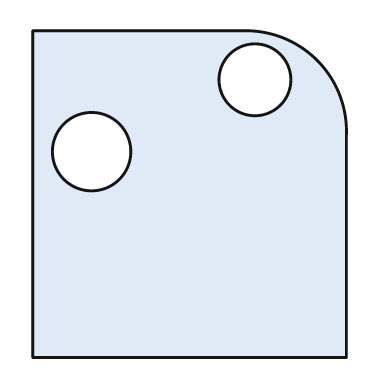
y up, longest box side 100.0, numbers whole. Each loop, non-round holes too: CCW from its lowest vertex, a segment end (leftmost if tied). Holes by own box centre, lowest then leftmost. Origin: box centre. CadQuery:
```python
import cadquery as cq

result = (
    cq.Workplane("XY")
    .moveTo(-48.0, -50.0)
    .lineTo(48.0, -50.0)
    .lineTo(48.0, 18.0)
    .threePointArc((39.0, 41.0), (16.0, 50.0))
    .lineTo(-48.0, 50.0)
    .close()
    .moveTo(-30.0, 13.0)
    .circle(12.0)
    .moveTo(20.0, 35.0)
    .circle(11.0)
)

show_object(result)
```